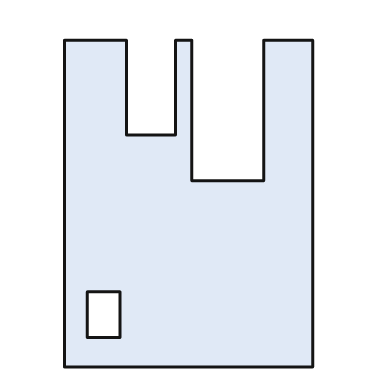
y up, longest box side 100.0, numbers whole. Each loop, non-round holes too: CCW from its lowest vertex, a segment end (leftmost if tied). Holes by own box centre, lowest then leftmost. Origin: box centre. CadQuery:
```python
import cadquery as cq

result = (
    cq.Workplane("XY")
    .moveTo(-38.0, -50.0)
    .lineTo(38.0, -50.0)
    .lineTo(38.0, 50.0)
    .lineTo(23.0, 50.0)
    .lineTo(23.0, 7.0)
    .lineTo(1.0, 7.0)
    .lineTo(1.0, 50.0)
    .lineTo(-4.0, 50.0)
    .lineTo(-4.0, 21.0)
    .lineTo(-19.0, 21.0)
    .lineTo(-19.0, 50.0)
    .lineTo(-38.0, 50.0)
    .close()
    .moveTo(-31.0, -41.0)
    .lineTo(-21.0, -41.0)
    .lineTo(-21.0, -27.0)
    .lineTo(-31.0, -27.0)
    .close()
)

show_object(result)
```